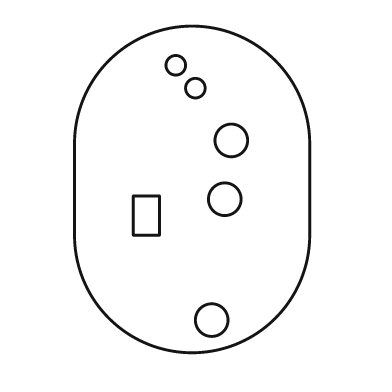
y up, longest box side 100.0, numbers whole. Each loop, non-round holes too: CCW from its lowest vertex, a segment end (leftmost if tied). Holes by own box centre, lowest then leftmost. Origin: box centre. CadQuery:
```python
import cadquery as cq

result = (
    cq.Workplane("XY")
    .moveTo(-36.0, -14.0)
    .threePointArc((0.0, -50.0), (36.0, -14.0))
    .lineTo(36.0, 14.0)
    .threePointArc((0.0, 50.0), (-36.0, 14.0))
    .close()
    .moveTo(6.0, -40.0)
    .circle(5.0)
    .moveTo(-18.0, -14.0)
    .lineTo(-10.0, -14.0)
    .lineTo(-10.0, -2.0)
    .lineTo(-18.0, -2.0)
    .close()
    .moveTo(10.0, -3.0)
    .circle(5.0)
    .moveTo(12.0, 15.0)
    .circle(5.0)
    .moveTo(1.0, 31.0)
    .circle(3.0)
    .moveTo(-5.0, 38.0)
    .circle(3.0)
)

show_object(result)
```